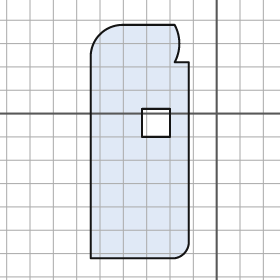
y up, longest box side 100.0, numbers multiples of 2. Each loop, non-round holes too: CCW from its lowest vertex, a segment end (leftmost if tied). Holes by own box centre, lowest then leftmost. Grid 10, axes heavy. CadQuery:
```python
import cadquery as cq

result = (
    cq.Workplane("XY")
    .moveTo(-54.0, -62.0)
    .lineTo(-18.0, -62.0)
    .threePointArc((-14.0, -60.0), (-12.0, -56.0))
    .lineTo(-12.0, 22.0)
    .lineTo(-18.0, 22.0)
    .threePointArc((-16.0, 30.0), (-18.0, 38.0))
    .lineTo(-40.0, 38.0)
    .threePointArc((-50.0, 34.0), (-54.0, 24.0))
    .close()
    .moveTo(-32.0, -10.0)
    .lineTo(-20.0, -10.0)
    .lineTo(-20.0, 2.0)
    .lineTo(-32.0, 2.0)
    .close()
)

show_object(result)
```